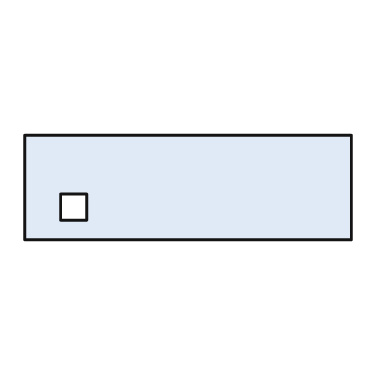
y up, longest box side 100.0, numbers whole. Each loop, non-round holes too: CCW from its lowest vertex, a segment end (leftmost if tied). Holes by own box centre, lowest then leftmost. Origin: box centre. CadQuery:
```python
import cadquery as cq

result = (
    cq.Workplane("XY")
    .moveTo(-50.0, -16.0)
    .lineTo(50.0, -16.0)
    .lineTo(50.0, 16.0)
    .lineTo(-50.0, 16.0)
    .close()
    .moveTo(-39.0, -10.0)
    .lineTo(-31.0, -10.0)
    .lineTo(-31.0, -2.0)
    .lineTo(-39.0, -2.0)
    .close()
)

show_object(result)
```